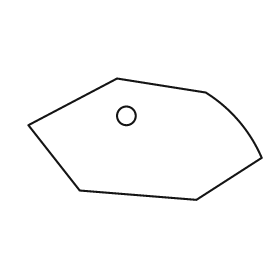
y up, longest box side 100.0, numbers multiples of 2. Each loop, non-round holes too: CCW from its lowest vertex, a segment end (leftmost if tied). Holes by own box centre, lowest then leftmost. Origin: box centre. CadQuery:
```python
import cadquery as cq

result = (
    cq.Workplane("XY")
    .moveTo(22.0, -26.0)
    .lineTo(50.0, -8.0)
    .threePointArc((40.0, 8.0), (26.0, 20.0))
    .lineTo(-12.0, 26.0)
    .lineTo(-50.0, 6.0)
    .lineTo(-28.0, -22.0)
    .close()
    .moveTo(-8.0, 10.0)
    .circle(4.0)
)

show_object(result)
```